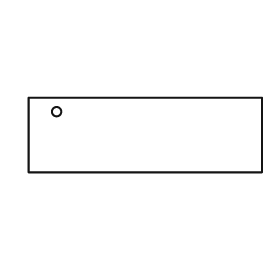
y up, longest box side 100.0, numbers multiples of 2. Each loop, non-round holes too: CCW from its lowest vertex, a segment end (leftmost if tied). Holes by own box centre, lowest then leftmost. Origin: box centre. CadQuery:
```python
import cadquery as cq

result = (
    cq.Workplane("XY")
    .moveTo(-50.0, -16.0)
    .lineTo(50.0, -16.0)
    .lineTo(50.0, 16.0)
    .lineTo(-50.0, 16.0)
    .close()
    .moveTo(-38.0, 10.0)
    .circle(2.0)
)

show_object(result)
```